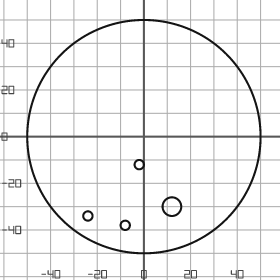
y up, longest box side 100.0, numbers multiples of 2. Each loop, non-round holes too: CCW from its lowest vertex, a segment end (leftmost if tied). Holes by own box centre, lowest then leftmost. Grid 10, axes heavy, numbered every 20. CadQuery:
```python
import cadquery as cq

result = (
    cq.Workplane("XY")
    .moveTo(0.0, 0.0)
    .circle(50.0)
    .moveTo(-8.0, -38.0)
    .circle(2.0)
    .moveTo(-24.0, -34.0)
    .circle(2.0)
    .moveTo(12.0, -30.0)
    .circle(4.0)
    .moveTo(-2.0, -12.0)
    .circle(2.0)
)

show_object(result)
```